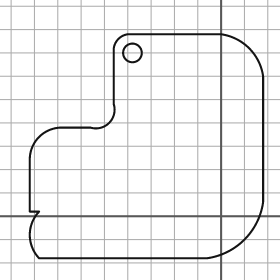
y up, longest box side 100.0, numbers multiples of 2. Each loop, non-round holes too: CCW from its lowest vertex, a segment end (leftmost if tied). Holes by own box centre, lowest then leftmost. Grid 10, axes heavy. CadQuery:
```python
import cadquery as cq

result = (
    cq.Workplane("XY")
    .moveTo(-78.0, -18.0)
    .lineTo(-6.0, -18.0)
    .threePointArc((10.0, -10.0), (18.0, 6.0))
    .lineTo(18.0, 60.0)
    .threePointArc((12.0, 72.0), (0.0, 78.0))
    .lineTo(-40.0, 78.0)
    .threePointArc((-44.0, 76.0), (-46.0, 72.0))
    .lineTo(-46.0, 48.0)
    .threePointArc((-48.0, 40.0), (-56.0, 38.0))
    .lineTo(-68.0, 38.0)
    .threePointArc((-78.0, 34.0), (-82.0, 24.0))
    .lineTo(-82.0, 2.0)
    .lineTo(-78.0, 2.0)
    .threePointArc((-82.0, -8.0), (-78.0, -18.0))
    .close()
    .moveTo(-38.0, 70.0)
    .circle(4.0)
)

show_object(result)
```